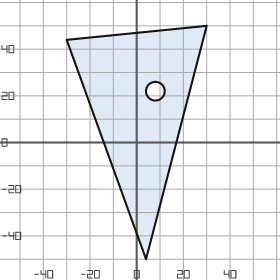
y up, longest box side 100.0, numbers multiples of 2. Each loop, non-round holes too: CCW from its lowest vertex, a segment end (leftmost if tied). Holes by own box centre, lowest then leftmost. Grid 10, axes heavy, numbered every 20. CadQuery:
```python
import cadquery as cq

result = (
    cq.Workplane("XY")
    .moveTo(4.0, -50.0)
    .lineTo(30.0, 50.0)
    .lineTo(-30.0, 44.0)
    .close()
    .moveTo(8.0, 22.0)
    .circle(4.0)
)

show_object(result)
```